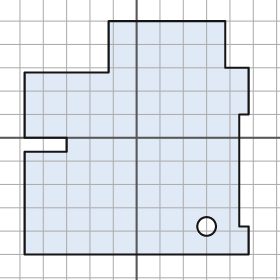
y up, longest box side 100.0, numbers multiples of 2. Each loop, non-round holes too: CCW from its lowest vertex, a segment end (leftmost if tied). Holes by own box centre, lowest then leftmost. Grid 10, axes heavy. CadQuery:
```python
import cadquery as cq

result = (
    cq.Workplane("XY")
    .moveTo(-48.0, -50.0)
    .lineTo(48.0, -50.0)
    .lineTo(48.0, -38.0)
    .lineTo(44.0, -38.0)
    .lineTo(44.0, 10.0)
    .lineTo(48.0, 10.0)
    .lineTo(48.0, 30.0)
    .lineTo(38.0, 30.0)
    .lineTo(38.0, 50.0)
    .lineTo(-12.0, 50.0)
    .lineTo(-12.0, 28.0)
    .lineTo(-48.0, 28.0)
    .lineTo(-48.0, 0.0)
    .lineTo(-30.0, 0.0)
    .lineTo(-30.0, -6.0)
    .lineTo(-48.0, -6.0)
    .close()
    .moveTo(30.0, -38.0)
    .circle(4.0)
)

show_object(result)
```